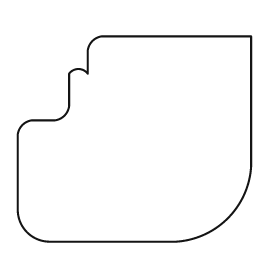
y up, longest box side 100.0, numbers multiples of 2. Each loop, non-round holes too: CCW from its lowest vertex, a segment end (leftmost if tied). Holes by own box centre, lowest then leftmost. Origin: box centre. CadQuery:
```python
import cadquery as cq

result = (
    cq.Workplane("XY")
    .moveTo(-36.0, -44.0)
    .lineTo(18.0, -44.0)
    .threePointArc((40.0, -34.0), (50.0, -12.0))
    .lineTo(50.0, 44.0)
    .lineTo(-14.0, 44.0)
    .threePointArc((-18.0, 42.0), (-20.0, 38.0))
    .lineTo(-20.0, 28.0)
    .threePointArc((-24.0, 30.0), (-28.0, 28.0))
    .lineTo(-28.0, 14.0)
    .threePointArc((-30.0, 10.0), (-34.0, 8.0))
    .lineTo(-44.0, 8.0)
    .threePointArc((-48.0, 6.0), (-50.0, 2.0))
    .lineTo(-50.0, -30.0)
    .threePointArc((-46.0, -40.0), (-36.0, -44.0))
    .close()
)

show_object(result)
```